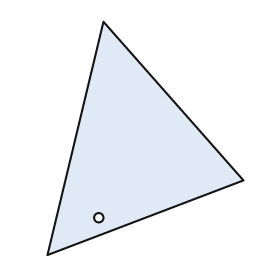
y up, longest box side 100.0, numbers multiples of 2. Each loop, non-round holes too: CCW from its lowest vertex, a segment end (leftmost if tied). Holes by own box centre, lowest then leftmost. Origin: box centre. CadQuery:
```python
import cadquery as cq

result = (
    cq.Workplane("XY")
    .moveTo(-42.0, -50.0)
    .lineTo(42.0, -18.0)
    .lineTo(-18.0, 50.0)
    .close()
    .moveTo(-20.0, -34.0)
    .circle(2.0)
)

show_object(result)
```